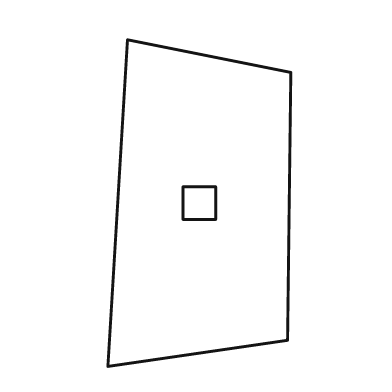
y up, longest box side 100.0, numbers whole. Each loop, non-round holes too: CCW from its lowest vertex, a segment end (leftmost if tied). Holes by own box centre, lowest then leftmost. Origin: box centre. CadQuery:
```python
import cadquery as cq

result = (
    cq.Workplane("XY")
    .moveTo(-28.0, -50.0)
    .lineTo(27.0, -42.0)
    .lineTo(28.0, 40.0)
    .lineTo(-22.0, 50.0)
    .close()
    .moveTo(-5.0, -5.0)
    .lineTo(5.0, -5.0)
    .lineTo(5.0, 5.0)
    .lineTo(-5.0, 5.0)
    .close()
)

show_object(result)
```